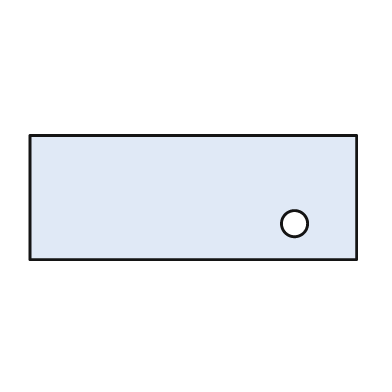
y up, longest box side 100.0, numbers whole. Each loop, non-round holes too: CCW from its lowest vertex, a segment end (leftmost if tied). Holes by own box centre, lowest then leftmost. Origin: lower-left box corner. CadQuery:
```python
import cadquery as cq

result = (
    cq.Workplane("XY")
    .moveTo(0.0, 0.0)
    .lineTo(100.0, 0.0)
    .lineTo(100.0, 38.0)
    .lineTo(0.0, 38.0)
    .close()
    .moveTo(81.0, 11.0)
    .circle(4.0)
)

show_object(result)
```